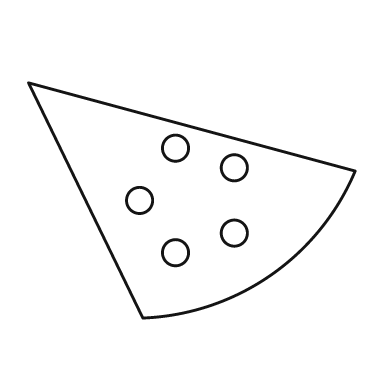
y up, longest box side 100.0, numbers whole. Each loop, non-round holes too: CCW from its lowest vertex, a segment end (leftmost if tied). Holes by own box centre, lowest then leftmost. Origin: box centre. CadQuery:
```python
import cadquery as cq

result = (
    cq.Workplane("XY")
    .moveTo(-15.0, -36.0)
    .threePointArc((24.0, -23.0), (50.0, 9.0))
    .lineTo(-50.0, 36.0)
    .close()
    .moveTo(-5.0, -16.0)
    .circle(4.0)
    .moveTo(13.0, -10.0)
    .circle(4.0)
    .moveTo(-16.0, 0.0)
    .circle(4.0)
    .moveTo(13.0, 10.0)
    .circle(4.0)
    .moveTo(-5.0, 16.0)
    .circle(4.0)
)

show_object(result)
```